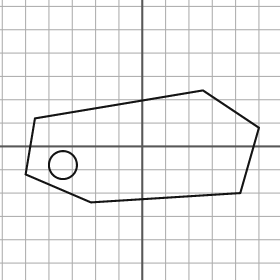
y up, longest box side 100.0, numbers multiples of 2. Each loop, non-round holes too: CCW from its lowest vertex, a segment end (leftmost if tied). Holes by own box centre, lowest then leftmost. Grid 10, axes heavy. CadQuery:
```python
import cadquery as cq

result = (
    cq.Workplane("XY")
    .moveTo(-22.0, -24.0)
    .lineTo(42.0, -20.0)
    .lineTo(50.0, 8.0)
    .lineTo(26.0, 24.0)
    .lineTo(-46.0, 12.0)
    .lineTo(-50.0, -12.0)
    .close()
    .moveTo(-34.0, -8.0)
    .circle(6.0)
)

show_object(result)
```